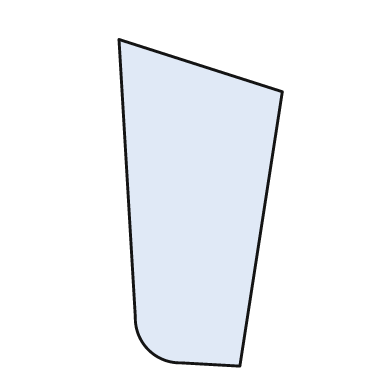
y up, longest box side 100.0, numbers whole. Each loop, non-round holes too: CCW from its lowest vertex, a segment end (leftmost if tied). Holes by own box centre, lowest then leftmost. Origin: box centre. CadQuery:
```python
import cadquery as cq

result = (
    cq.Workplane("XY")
    .moveTo(12.0, -50.0)
    .lineTo(25.0, 34.0)
    .lineTo(-25.0, 50.0)
    .lineTo(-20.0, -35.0)
    .threePointArc((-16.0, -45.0), (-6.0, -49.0))
    .close()
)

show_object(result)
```